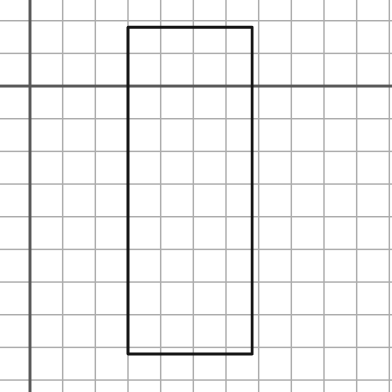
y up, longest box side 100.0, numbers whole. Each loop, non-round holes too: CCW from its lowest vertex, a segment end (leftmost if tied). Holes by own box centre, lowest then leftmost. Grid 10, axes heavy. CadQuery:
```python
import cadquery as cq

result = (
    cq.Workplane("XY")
    .moveTo(30.0, -82.0)
    .lineTo(68.0, -82.0)
    .lineTo(68.0, 18.0)
    .lineTo(30.0, 18.0)
    .close()
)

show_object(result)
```